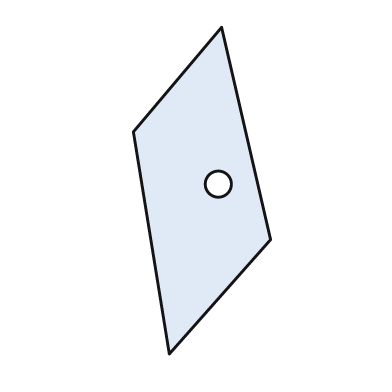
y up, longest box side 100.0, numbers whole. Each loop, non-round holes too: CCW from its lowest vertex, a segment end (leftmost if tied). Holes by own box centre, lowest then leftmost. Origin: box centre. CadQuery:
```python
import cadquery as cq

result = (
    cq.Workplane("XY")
    .moveTo(-10.0, -50.0)
    .lineTo(21.0, -15.0)
    .lineTo(6.0, 50.0)
    .lineTo(-21.0, 18.0)
    .close()
    .moveTo(5.0, 2.0)
    .circle(4.0)
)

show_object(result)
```